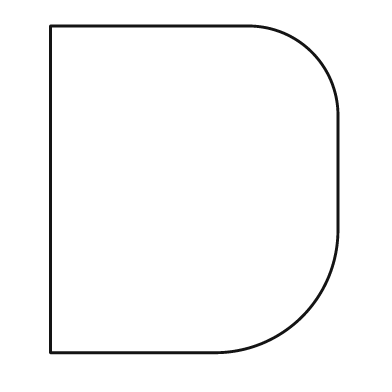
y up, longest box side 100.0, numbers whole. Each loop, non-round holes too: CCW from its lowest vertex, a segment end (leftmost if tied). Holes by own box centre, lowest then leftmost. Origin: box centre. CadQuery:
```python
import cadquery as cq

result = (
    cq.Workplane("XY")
    .moveTo(-44.0, -50.0)
    .lineTo(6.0, -50.0)
    .threePointArc((33.0, -39.0), (44.0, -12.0))
    .lineTo(44.0, 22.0)
    .threePointArc((36.0, 42.0), (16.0, 50.0))
    .lineTo(-44.0, 50.0)
    .close()
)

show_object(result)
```